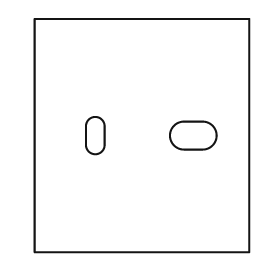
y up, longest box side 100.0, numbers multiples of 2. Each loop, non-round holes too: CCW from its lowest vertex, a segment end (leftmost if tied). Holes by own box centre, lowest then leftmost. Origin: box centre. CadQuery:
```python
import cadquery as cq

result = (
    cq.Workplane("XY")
    .moveTo(-46.0, -50.0)
    .lineTo(46.0, -50.0)
    .lineTo(46.0, 50.0)
    .lineTo(-46.0, 50.0)
    .close()
    .moveTo(-24.0, -4.0)
    .threePointArc((-20.0, -8.0), (-16.0, -4.0))
    .lineTo(-16.0, 4.0)
    .threePointArc((-20.0, 8.0), (-24.0, 4.0))
    .close()
    .moveTo(18.0, -6.0)
    .lineTo(26.0, -6.0)
    .threePointArc((32.0, 0.0), (26.0, 6.0))
    .lineTo(18.0, 6.0)
    .threePointArc((12.0, 0.0), (18.0, -6.0))
    .close()
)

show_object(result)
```